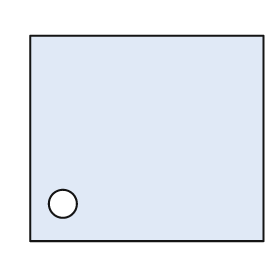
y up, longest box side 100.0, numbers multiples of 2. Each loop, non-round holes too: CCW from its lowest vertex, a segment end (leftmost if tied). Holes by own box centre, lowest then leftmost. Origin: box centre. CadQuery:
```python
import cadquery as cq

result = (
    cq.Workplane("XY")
    .moveTo(-50.0, -44.0)
    .lineTo(50.0, -44.0)
    .lineTo(50.0, 44.0)
    .lineTo(-50.0, 44.0)
    .close()
    .moveTo(-36.0, -28.0)
    .circle(6.0)
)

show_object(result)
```